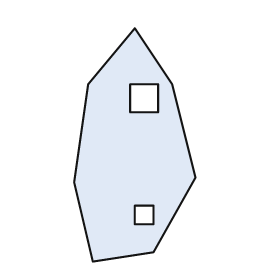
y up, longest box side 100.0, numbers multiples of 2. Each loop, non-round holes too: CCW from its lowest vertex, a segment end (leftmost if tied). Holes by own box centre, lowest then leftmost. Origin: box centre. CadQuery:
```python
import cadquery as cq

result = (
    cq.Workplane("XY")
    .moveTo(-18.0, -50.0)
    .lineTo(8.0, -46.0)
    .lineTo(26.0, -14.0)
    .lineTo(16.0, 26.0)
    .lineTo(0.0, 50.0)
    .lineTo(-20.0, 26.0)
    .lineTo(-26.0, -16.0)
    .close()
    .moveTo(0.0, -34.0)
    .lineTo(8.0, -34.0)
    .lineTo(8.0, -26.0)
    .lineTo(0.0, -26.0)
    .close()
    .moveTo(-2.0, 14.0)
    .lineTo(10.0, 14.0)
    .lineTo(10.0, 26.0)
    .lineTo(-2.0, 26.0)
    .close()
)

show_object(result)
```